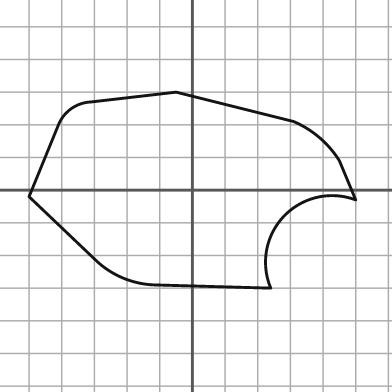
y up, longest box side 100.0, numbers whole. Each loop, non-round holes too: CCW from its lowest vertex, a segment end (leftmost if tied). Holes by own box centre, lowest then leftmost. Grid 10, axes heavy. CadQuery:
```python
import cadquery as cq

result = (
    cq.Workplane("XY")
    .moveTo(24.0, -30.0)
    .threePointArc((28.0, -8.0), (50.0, -3.0))
    .lineTo(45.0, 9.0)
    .threePointArc((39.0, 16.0), (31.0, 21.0))
    .lineTo(-5.0, 30.0)
    .lineTo(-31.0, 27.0)
    .threePointArc((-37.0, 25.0), (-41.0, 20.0))
    .lineTo(-50.0, -2.0)
    .lineTo(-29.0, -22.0)
    .threePointArc((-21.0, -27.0), (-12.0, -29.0))
    .close()
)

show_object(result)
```